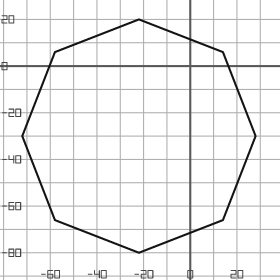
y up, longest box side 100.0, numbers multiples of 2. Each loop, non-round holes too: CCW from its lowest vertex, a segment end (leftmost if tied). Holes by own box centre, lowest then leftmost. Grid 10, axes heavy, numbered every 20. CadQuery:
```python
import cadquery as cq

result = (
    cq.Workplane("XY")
    .moveTo(-22.0, -80.0)
    .lineTo(14.0, -66.0)
    .lineTo(28.0, -30.0)
    .lineTo(14.0, 6.0)
    .lineTo(-22.0, 20.0)
    .lineTo(-58.0, 6.0)
    .lineTo(-72.0, -30.0)
    .lineTo(-58.0, -66.0)
    .close()
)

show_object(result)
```